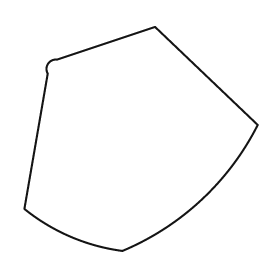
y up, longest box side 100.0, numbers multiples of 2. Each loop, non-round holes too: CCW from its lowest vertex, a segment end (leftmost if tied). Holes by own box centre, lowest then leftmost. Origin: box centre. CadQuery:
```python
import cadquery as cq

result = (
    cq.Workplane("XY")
    .moveTo(-8.0, -48.0)
    .threePointArc((26.0, -26.0), (50.0, 6.0))
    .lineTo(6.0, 48.0)
    .lineTo(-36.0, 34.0)
    .threePointArc((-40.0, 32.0), (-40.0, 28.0))
    .lineTo(-50.0, -30.0)
    .threePointArc((-30.0, -42.0), (-8.0, -48.0))
    .close()
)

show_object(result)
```